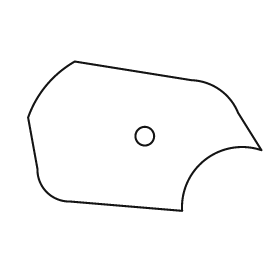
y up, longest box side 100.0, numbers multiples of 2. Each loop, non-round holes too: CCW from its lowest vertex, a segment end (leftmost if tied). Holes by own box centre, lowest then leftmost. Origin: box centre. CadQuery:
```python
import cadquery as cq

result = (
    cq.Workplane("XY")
    .moveTo(16.0, -32.0)
    .threePointArc((26.0, -10.0), (50.0, -6.0))
    .lineTo(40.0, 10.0)
    .threePointArc((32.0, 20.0), (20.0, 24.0))
    .lineTo(-30.0, 32.0)
    .threePointArc((-42.0, 22.0), (-50.0, 8.0))
    .lineTo(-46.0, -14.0)
    .threePointArc((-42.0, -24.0), (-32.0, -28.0))
    .close()
    .moveTo(0.0, 0.0)
    .circle(4.0)
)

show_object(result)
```